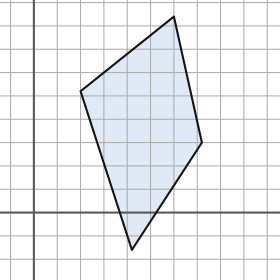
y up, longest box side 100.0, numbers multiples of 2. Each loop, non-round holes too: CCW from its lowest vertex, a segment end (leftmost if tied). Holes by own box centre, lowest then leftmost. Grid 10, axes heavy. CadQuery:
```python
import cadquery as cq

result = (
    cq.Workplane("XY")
    .moveTo(42.0, -16.0)
    .lineTo(72.0, 30.0)
    .lineTo(60.0, 84.0)
    .lineTo(20.0, 52.0)
    .close()
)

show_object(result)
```